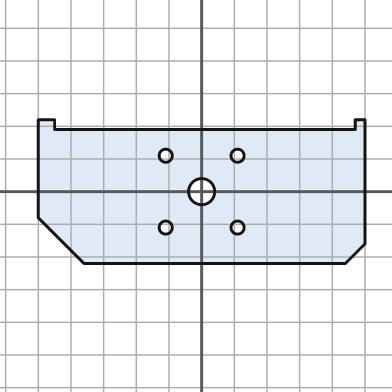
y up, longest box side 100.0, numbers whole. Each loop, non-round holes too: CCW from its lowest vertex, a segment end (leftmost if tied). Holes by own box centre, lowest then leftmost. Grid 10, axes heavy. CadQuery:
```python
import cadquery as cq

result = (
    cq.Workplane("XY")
    .moveTo(-36.0, -22.0)
    .lineTo(44.0, -22.0)
    .lineTo(50.0, -16.0)
    .lineTo(50.0, 22.0)
    .lineTo(47.0, 22.0)
    .lineTo(47.0, 19.0)
    .lineTo(-45.0, 19.0)
    .lineTo(-45.0, 22.0)
    .lineTo(-50.0, 22.0)
    .lineTo(-50.0, -8.0)
    .close()
    .moveTo(-11.0, -11.0)
    .circle(2.0)
    .moveTo(11.0, -11.0)
    .circle(2.0)
    .moveTo(0.0, 0.0)
    .circle(4.0)
    .moveTo(-11.0, 11.0)
    .circle(2.0)
    .moveTo(11.0, 11.0)
    .circle(2.0)
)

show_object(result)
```